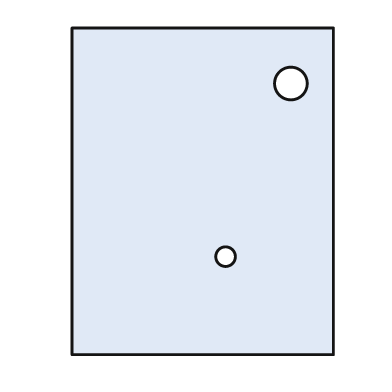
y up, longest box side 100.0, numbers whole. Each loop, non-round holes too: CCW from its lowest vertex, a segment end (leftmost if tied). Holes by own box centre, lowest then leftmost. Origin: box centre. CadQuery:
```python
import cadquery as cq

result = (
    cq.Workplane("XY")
    .moveTo(-40.0, -50.0)
    .lineTo(40.0, -50.0)
    .lineTo(40.0, 50.0)
    .lineTo(-40.0, 50.0)
    .close()
    .moveTo(7.0, -20.0)
    .circle(3.0)
    .moveTo(27.0, 33.0)
    .circle(5.0)
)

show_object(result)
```